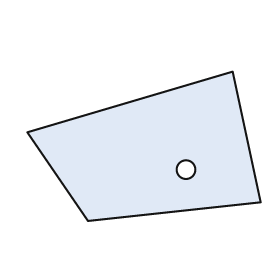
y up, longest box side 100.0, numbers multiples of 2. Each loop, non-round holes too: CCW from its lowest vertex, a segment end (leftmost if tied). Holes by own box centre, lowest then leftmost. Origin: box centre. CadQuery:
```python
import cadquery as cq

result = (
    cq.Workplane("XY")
    .moveTo(-24.0, -32.0)
    .lineTo(50.0, -24.0)
    .lineTo(38.0, 32.0)
    .lineTo(-50.0, 6.0)
    .close()
    .moveTo(18.0, -10.0)
    .circle(4.0)
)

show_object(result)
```